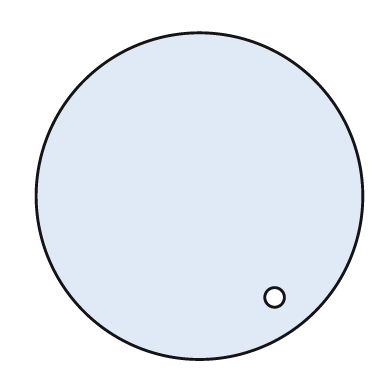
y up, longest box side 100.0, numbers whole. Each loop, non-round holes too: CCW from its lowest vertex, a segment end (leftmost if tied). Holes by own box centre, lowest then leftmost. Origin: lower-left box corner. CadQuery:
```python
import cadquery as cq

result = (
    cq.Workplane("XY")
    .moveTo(50.0, 50.0)
    .circle(50.0)
    .moveTo(73.0, 19.0)
    .circle(3.0)
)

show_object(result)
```